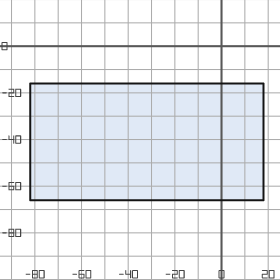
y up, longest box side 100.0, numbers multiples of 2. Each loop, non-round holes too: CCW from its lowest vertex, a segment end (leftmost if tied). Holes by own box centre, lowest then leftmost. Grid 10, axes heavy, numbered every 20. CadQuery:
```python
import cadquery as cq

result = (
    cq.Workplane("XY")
    .moveTo(-82.0, -66.0)
    .lineTo(18.0, -66.0)
    .lineTo(18.0, -16.0)
    .lineTo(-82.0, -16.0)
    .close()
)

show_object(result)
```